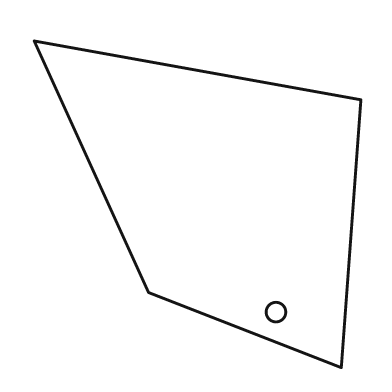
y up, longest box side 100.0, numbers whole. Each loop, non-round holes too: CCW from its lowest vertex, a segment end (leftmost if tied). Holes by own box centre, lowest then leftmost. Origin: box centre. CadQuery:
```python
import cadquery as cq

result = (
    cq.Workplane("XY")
    .moveTo(44.0, -50.0)
    .lineTo(50.0, 32.0)
    .lineTo(-50.0, 50.0)
    .lineTo(-15.0, -27.0)
    .close()
    .moveTo(24.0, -33.0)
    .circle(3.0)
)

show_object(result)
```